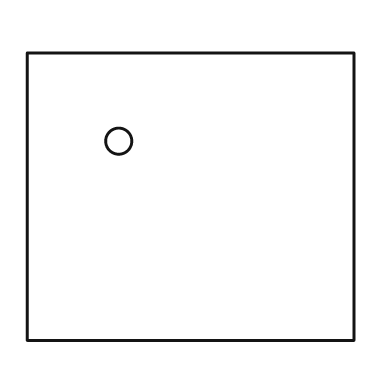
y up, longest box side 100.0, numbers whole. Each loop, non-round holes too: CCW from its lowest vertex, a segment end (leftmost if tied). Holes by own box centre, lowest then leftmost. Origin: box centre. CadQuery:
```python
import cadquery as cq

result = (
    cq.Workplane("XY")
    .moveTo(-50.0, -44.0)
    .lineTo(50.0, -44.0)
    .lineTo(50.0, 44.0)
    .lineTo(-50.0, 44.0)
    .close()
    .moveTo(-22.0, 17.0)
    .circle(4.0)
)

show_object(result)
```